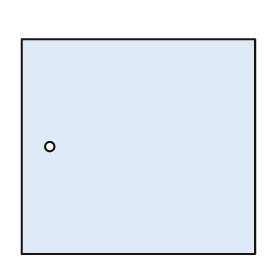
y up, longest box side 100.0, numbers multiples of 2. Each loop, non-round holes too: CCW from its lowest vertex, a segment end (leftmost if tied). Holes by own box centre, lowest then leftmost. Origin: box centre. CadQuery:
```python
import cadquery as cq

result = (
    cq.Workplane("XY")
    .moveTo(-50.0, -46.0)
    .lineTo(50.0, -46.0)
    .lineTo(50.0, 46.0)
    .lineTo(-50.0, 46.0)
    .close()
    .moveTo(-38.0, 0.0)
    .circle(2.0)
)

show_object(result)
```